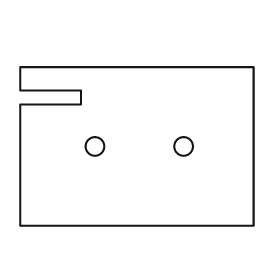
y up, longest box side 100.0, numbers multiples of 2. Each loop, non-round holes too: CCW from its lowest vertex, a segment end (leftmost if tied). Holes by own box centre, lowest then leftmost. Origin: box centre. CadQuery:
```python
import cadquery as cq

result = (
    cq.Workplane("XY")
    .moveTo(-50.0, -34.0)
    .lineTo(50.0, -34.0)
    .lineTo(50.0, 34.0)
    .lineTo(-50.0, 34.0)
    .lineTo(-50.0, 24.0)
    .lineTo(-24.0, 24.0)
    .lineTo(-24.0, 18.0)
    .lineTo(-50.0, 18.0)
    .close()
    .moveTo(-18.0, 0.0)
    .circle(4.0)
    .moveTo(20.0, 0.0)
    .circle(4.0)
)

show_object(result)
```